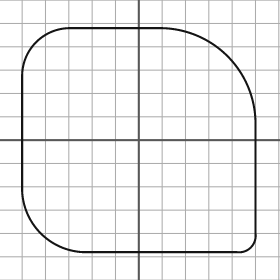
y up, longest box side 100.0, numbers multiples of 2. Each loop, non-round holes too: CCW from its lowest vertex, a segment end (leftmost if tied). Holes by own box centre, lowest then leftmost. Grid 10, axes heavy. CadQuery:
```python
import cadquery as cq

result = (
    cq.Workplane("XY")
    .moveTo(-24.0, -48.0)
    .lineTo(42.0, -48.0)
    .threePointArc((48.0, -46.0), (50.0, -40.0))
    .lineTo(50.0, 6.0)
    .threePointArc((38.0, 36.0), (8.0, 48.0))
    .lineTo(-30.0, 48.0)
    .threePointArc((-44.0, 42.0), (-50.0, 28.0))
    .lineTo(-50.0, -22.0)
    .threePointArc((-42.0, -40.0), (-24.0, -48.0))
    .close()
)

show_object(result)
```